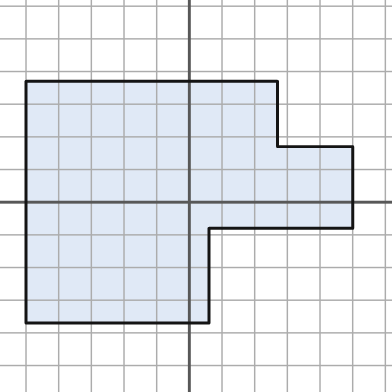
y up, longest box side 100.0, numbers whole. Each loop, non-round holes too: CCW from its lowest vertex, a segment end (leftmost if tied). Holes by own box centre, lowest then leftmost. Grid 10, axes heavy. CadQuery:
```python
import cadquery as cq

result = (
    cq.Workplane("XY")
    .moveTo(-50.0, -37.0)
    .lineTo(6.0, -37.0)
    .lineTo(6.0, -8.0)
    .lineTo(50.0, -8.0)
    .lineTo(50.0, 17.0)
    .lineTo(27.0, 17.0)
    .lineTo(27.0, 37.0)
    .lineTo(-50.0, 37.0)
    .close()
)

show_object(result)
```